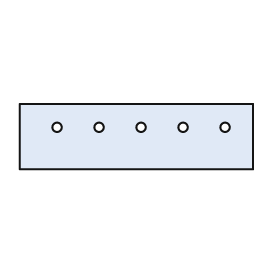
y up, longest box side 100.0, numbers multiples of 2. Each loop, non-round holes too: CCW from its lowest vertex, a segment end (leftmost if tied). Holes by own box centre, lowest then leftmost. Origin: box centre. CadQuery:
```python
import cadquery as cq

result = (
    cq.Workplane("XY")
    .moveTo(-50.0, -14.0)
    .lineTo(50.0, -14.0)
    .lineTo(50.0, 14.0)
    .lineTo(-50.0, 14.0)
    .close()
    .moveTo(-34.0, 4.0)
    .circle(2.0)
    .moveTo(-16.0, 4.0)
    .circle(2.0)
    .moveTo(2.0, 4.0)
    .circle(2.0)
    .moveTo(20.0, 4.0)
    .circle(2.0)
    .moveTo(38.0, 4.0)
    .circle(2.0)
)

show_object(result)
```